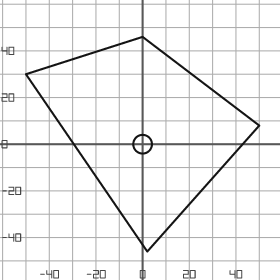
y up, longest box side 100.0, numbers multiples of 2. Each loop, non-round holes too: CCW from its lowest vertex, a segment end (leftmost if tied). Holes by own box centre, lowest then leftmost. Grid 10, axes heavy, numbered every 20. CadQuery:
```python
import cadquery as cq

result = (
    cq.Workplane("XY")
    .moveTo(2.0, -46.0)
    .lineTo(50.0, 8.0)
    .lineTo(0.0, 46.0)
    .lineTo(-50.0, 30.0)
    .close()
    .moveTo(0.0, 0.0)
    .circle(4.0)
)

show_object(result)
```